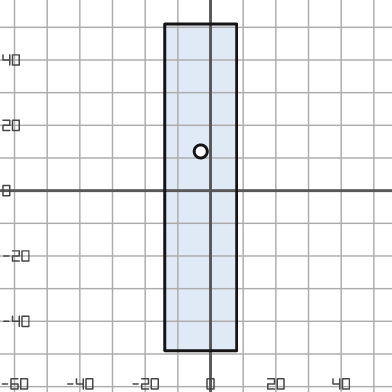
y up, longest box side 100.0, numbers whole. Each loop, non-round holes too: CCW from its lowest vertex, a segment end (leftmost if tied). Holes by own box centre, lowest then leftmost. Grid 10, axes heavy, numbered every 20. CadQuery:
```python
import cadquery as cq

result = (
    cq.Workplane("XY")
    .moveTo(-14.0, -49.0)
    .lineTo(8.0, -49.0)
    .lineTo(8.0, 51.0)
    .lineTo(-14.0, 51.0)
    .close()
    .moveTo(-3.0, 12.0)
    .circle(2.0)
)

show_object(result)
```